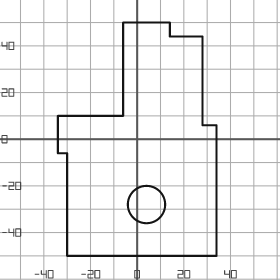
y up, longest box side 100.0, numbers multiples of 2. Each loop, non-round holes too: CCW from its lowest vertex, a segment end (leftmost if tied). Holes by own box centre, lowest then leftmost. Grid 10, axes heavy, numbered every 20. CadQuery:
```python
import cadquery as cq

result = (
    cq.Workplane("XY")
    .moveTo(-30.0, -50.0)
    .lineTo(34.0, -50.0)
    .lineTo(34.0, 6.0)
    .lineTo(28.0, 6.0)
    .lineTo(28.0, 44.0)
    .lineTo(14.0, 44.0)
    .lineTo(14.0, 50.0)
    .lineTo(-6.0, 50.0)
    .lineTo(-6.0, 10.0)
    .lineTo(-34.0, 10.0)
    .lineTo(-34.0, -6.0)
    .lineTo(-30.0, -6.0)
    .close()
    .moveTo(4.0, -28.0)
    .circle(8.0)
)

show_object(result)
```